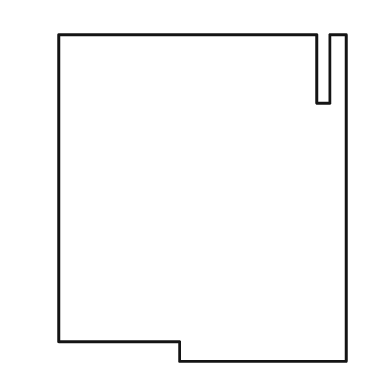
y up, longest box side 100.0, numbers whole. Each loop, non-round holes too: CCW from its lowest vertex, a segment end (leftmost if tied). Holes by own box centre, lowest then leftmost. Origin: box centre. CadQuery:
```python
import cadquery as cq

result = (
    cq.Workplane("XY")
    .moveTo(-7.0, -50.0)
    .lineTo(44.0, -50.0)
    .lineTo(44.0, 50.0)
    .lineTo(39.0, 50.0)
    .lineTo(39.0, 29.0)
    .lineTo(35.0, 29.0)
    .lineTo(35.0, 50.0)
    .lineTo(-44.0, 50.0)
    .lineTo(-44.0, -44.0)
    .lineTo(-7.0, -44.0)
    .close()
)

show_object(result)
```